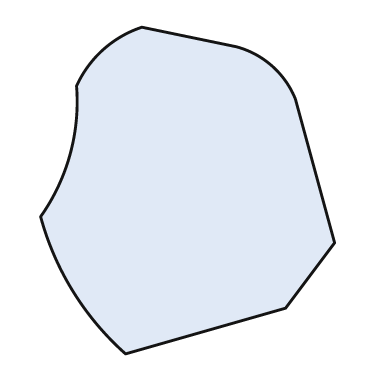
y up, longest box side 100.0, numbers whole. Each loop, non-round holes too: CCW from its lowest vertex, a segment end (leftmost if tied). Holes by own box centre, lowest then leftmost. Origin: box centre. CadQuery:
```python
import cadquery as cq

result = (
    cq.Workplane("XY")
    .moveTo(-19.0, -50.0)
    .lineTo(30.0, -36.0)
    .lineTo(45.0, -16.0)
    .lineTo(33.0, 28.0)
    .threePointArc((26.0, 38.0), (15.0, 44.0))
    .lineTo(-14.0, 50.0)
    .threePointArc((-26.0, 43.0), (-34.0, 32.0))
    .threePointArc((-36.0, 11.0), (-45.0, -8.0))
    .threePointArc((-35.0, -31.0), (-19.0, -50.0))
    .close()
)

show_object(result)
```